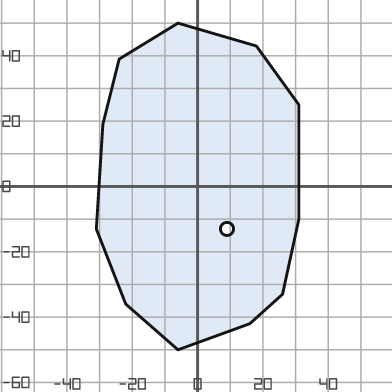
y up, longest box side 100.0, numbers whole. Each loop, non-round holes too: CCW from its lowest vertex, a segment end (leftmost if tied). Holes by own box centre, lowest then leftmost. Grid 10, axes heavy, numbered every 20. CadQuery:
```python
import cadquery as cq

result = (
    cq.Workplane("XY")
    .moveTo(-6.0, -50.0)
    .lineTo(16.0, -42.0)
    .lineTo(26.0, -33.0)
    .lineTo(31.0, -10.0)
    .lineTo(31.0, 25.0)
    .lineTo(18.0, 43.0)
    .lineTo(-6.0, 50.0)
    .lineTo(-24.0, 39.0)
    .lineTo(-29.0, 19.0)
    .lineTo(-31.0, -13.0)
    .lineTo(-22.0, -36.0)
    .close()
    .moveTo(9.0, -13.0)
    .circle(2.0)
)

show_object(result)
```